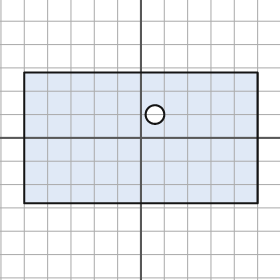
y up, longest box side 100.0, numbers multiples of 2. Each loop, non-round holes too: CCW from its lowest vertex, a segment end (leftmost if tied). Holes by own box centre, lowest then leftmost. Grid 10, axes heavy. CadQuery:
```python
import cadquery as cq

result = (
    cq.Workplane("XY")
    .moveTo(-50.0, -28.0)
    .lineTo(50.0, -28.0)
    .lineTo(50.0, 28.0)
    .lineTo(-50.0, 28.0)
    .close()
    .moveTo(6.0, 10.0)
    .circle(4.0)
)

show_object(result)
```